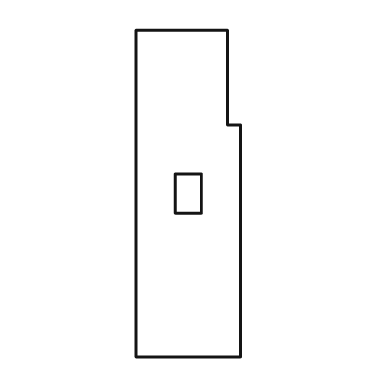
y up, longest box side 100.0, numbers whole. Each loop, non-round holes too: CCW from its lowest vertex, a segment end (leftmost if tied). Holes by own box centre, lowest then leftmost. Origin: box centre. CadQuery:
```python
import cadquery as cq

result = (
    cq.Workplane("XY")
    .moveTo(-16.0, -50.0)
    .lineTo(16.0, -50.0)
    .lineTo(16.0, 21.0)
    .lineTo(12.0, 21.0)
    .lineTo(12.0, 50.0)
    .lineTo(-16.0, 50.0)
    .close()
    .moveTo(-4.0, -6.0)
    .lineTo(4.0, -6.0)
    .lineTo(4.0, 6.0)
    .lineTo(-4.0, 6.0)
    .close()
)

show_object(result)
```